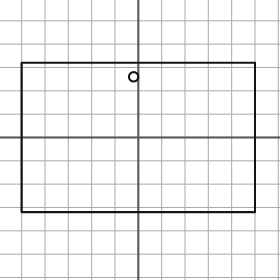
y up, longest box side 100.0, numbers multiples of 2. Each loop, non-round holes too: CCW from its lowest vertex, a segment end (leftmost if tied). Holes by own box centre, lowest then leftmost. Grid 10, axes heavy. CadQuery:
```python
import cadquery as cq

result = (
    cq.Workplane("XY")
    .moveTo(-50.0, -32.0)
    .lineTo(50.0, -32.0)
    .lineTo(50.0, 32.0)
    .lineTo(-50.0, 32.0)
    .close()
    .moveTo(-2.0, 26.0)
    .circle(2.0)
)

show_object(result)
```